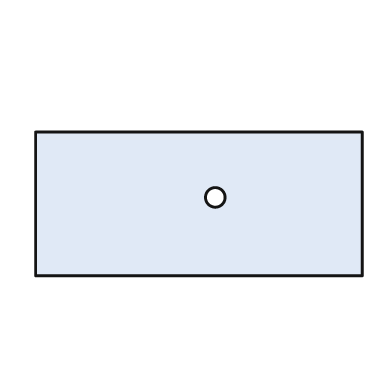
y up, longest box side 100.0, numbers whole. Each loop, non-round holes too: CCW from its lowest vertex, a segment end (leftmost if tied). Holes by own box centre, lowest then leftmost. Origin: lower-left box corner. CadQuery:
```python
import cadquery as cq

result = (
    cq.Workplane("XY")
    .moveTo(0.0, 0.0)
    .lineTo(100.0, 0.0)
    .lineTo(100.0, 44.0)
    .lineTo(0.0, 44.0)
    .close()
    .moveTo(55.0, 24.0)
    .circle(3.0)
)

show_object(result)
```